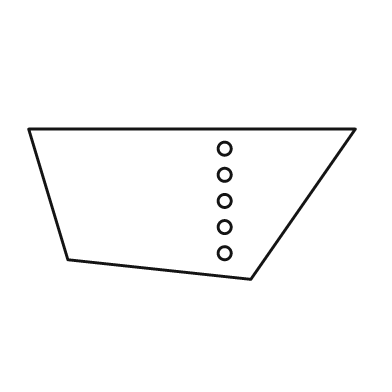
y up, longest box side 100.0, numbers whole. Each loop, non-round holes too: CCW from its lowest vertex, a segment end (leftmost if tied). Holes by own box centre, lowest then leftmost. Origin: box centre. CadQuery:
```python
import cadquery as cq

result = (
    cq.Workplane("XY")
    .moveTo(18.0, -23.0)
    .lineTo(50.0, 23.0)
    .lineTo(-50.0, 23.0)
    .lineTo(-38.0, -17.0)
    .close()
    .moveTo(10.0, -15.0)
    .circle(2.0)
    .moveTo(10.0, -7.0)
    .circle(2.0)
    .moveTo(10.0, 1.0)
    .circle(2.0)
    .moveTo(10.0, 9.0)
    .circle(2.0)
    .moveTo(10.0, 17.0)
    .circle(2.0)
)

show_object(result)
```